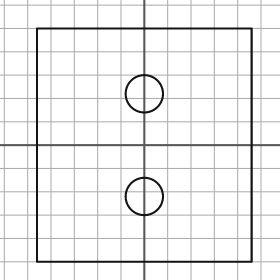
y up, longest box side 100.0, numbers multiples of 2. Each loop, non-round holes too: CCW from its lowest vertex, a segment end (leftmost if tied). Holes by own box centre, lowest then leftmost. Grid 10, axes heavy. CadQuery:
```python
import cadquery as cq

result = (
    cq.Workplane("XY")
    .moveTo(-46.0, -50.0)
    .lineTo(46.0, -50.0)
    .lineTo(46.0, 50.0)
    .lineTo(-46.0, 50.0)
    .close()
    .moveTo(0.0, -22.0)
    .circle(8.0)
    .moveTo(0.0, 22.0)
    .circle(8.0)
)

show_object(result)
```